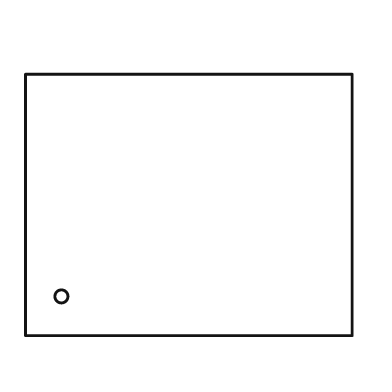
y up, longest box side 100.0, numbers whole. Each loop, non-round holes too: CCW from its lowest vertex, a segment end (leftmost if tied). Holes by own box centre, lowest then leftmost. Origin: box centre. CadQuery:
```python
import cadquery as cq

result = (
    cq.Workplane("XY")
    .moveTo(-50.0, -40.0)
    .lineTo(50.0, -40.0)
    .lineTo(50.0, 40.0)
    .lineTo(-50.0, 40.0)
    .close()
    .moveTo(-39.0, -28.0)
    .circle(2.0)
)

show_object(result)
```